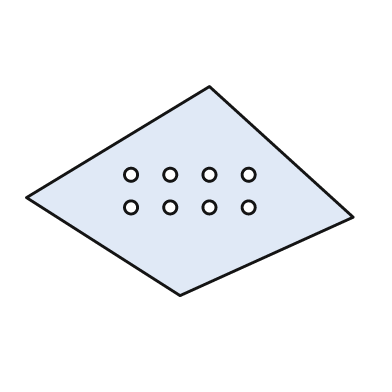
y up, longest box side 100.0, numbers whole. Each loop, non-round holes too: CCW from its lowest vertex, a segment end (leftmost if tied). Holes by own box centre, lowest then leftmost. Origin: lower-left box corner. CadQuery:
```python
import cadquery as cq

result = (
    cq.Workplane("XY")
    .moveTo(47.0, 0.0)
    .lineTo(100.0, 24.0)
    .lineTo(56.0, 64.0)
    .lineTo(0.0, 30.0)
    .close()
    .moveTo(32.0, 27.0)
    .circle(2.0)
    .moveTo(44.0, 27.0)
    .circle(2.0)
    .moveTo(56.0, 27.0)
    .circle(2.0)
    .moveTo(68.0, 27.0)
    .circle(2.0)
    .moveTo(32.0, 37.0)
    .circle(2.0)
    .moveTo(44.0, 37.0)
    .circle(2.0)
    .moveTo(56.0, 37.0)
    .circle(2.0)
    .moveTo(68.0, 37.0)
    .circle(2.0)
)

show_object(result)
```